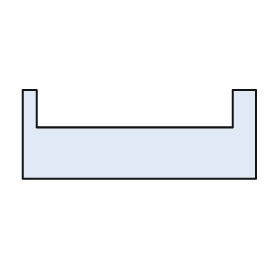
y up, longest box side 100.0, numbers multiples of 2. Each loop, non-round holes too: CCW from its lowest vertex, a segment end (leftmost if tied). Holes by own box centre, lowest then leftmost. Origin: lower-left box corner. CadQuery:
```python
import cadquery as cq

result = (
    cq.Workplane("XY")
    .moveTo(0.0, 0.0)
    .lineTo(100.0, 0.0)
    .lineTo(100.0, 38.0)
    .lineTo(90.0, 38.0)
    .lineTo(90.0, 22.0)
    .lineTo(6.0, 22.0)
    .lineTo(6.0, 38.0)
    .lineTo(0.0, 38.0)
    .close()
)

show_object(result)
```